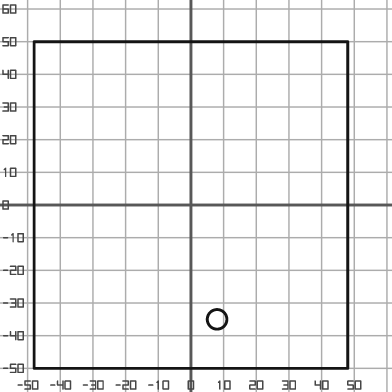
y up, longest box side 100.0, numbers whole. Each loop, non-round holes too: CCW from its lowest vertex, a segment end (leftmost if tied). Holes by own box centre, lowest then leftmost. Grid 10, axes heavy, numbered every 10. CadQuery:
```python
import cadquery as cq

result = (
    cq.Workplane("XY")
    .moveTo(-48.0, -50.0)
    .lineTo(48.0, -50.0)
    .lineTo(48.0, 50.0)
    .lineTo(-48.0, 50.0)
    .close()
    .moveTo(8.0, -35.0)
    .circle(3.0)
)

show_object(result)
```